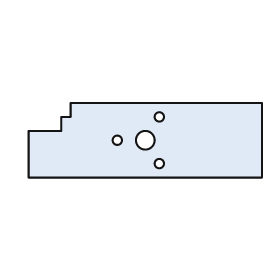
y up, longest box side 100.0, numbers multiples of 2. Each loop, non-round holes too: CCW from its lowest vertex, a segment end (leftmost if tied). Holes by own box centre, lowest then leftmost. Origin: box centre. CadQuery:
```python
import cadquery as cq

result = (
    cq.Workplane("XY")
    .moveTo(-50.0, -16.0)
    .lineTo(50.0, -16.0)
    .lineTo(50.0, 16.0)
    .lineTo(-32.0, 16.0)
    .lineTo(-32.0, 10.0)
    .lineTo(-36.0, 10.0)
    .lineTo(-36.0, 4.0)
    .lineTo(-50.0, 4.0)
    .close()
    .moveTo(6.0, -10.0)
    .circle(2.0)
    .moveTo(-12.0, 0.0)
    .circle(2.0)
    .moveTo(0.0, 0.0)
    .circle(4.0)
    .moveTo(6.0, 10.0)
    .circle(2.0)
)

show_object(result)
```